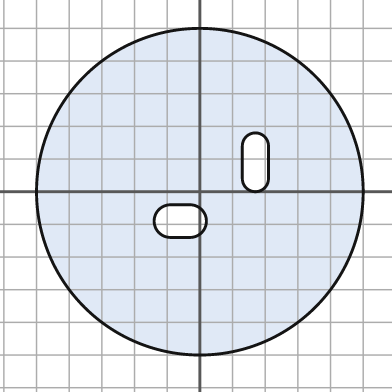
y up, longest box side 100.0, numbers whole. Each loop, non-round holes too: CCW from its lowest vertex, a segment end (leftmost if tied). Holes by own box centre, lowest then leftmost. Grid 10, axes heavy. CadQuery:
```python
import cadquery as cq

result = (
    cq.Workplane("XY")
    .moveTo(0.0, 0.0)
    .circle(50.0)
    .moveTo(-9.0, -14.0)
    .lineTo(-3.0, -14.0)
    .threePointArc((2.0, -9.0), (-3.0, -4.0))
    .lineTo(-9.0, -4.0)
    .threePointArc((-14.0, -9.0), (-9.0, -14.0))
    .close()
    .moveTo(13.0, 4.0)
    .threePointArc((17.0, 0.0), (21.0, 4.0))
    .lineTo(21.0, 14.0)
    .threePointArc((17.0, 18.0), (13.0, 14.0))
    .close()
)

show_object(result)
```